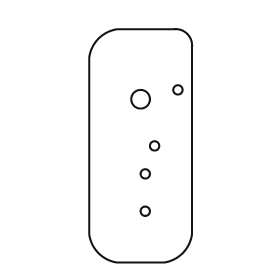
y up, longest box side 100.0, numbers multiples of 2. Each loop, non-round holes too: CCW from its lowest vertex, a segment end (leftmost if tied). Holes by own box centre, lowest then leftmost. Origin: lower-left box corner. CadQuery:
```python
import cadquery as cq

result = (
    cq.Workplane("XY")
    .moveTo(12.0, 0.0)
    .lineTo(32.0, 0.0)
    .threePointArc((40.0, 4.0), (44.0, 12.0))
    .lineTo(44.0, 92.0)
    .threePointArc((42.0, 98.0), (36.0, 100.0))
    .lineTo(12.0, 100.0)
    .threePointArc((4.0, 96.0), (0.0, 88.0))
    .lineTo(0.0, 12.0)
    .threePointArc((4.0, 4.0), (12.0, 0.0))
    .close()
    .moveTo(24.0, 22.0)
    .circle(2.0)
    .moveTo(24.0, 38.0)
    .circle(2.0)
    .moveTo(28.0, 50.0)
    .circle(2.0)
    .moveTo(22.0, 70.0)
    .circle(4.0)
    .moveTo(38.0, 74.0)
    .circle(2.0)
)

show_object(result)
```